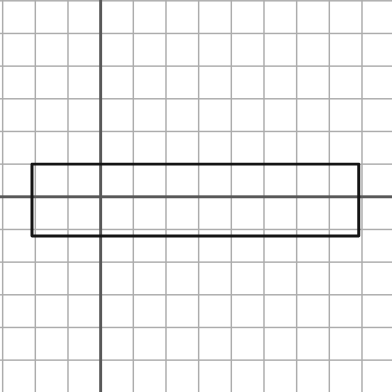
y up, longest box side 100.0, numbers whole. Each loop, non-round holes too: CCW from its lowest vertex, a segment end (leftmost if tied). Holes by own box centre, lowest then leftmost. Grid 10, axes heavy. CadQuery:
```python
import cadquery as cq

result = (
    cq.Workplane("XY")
    .moveTo(-21.0, -12.0)
    .lineTo(79.0, -12.0)
    .lineTo(79.0, 10.0)
    .lineTo(-21.0, 10.0)
    .close()
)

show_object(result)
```